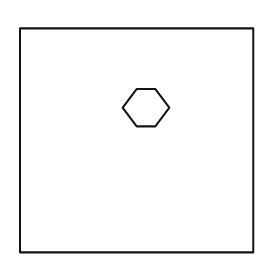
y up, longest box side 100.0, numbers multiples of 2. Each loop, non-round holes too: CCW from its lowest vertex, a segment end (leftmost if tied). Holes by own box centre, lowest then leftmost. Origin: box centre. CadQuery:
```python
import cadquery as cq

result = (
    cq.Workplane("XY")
    .moveTo(-50.0, -48.0)
    .lineTo(50.0, -48.0)
    .lineTo(50.0, 48.0)
    .lineTo(-50.0, 48.0)
    .close()
    .moveTo(0.0, 6.0)
    .lineTo(8.0, 6.0)
    .lineTo(14.0, 14.0)
    .lineTo(8.0, 22.0)
    .lineTo(0.0, 22.0)
    .lineTo(-6.0, 14.0)
    .close()
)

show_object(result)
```